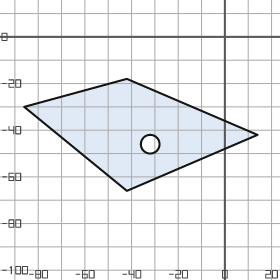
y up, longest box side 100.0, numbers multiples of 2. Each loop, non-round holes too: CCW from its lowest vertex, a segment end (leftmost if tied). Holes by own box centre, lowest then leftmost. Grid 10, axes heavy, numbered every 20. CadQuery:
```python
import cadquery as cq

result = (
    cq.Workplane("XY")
    .moveTo(-42.0, -66.0)
    .lineTo(14.0, -42.0)
    .lineTo(-42.0, -18.0)
    .lineTo(-86.0, -30.0)
    .close()
    .moveTo(-32.0, -46.0)
    .circle(4.0)
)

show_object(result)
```